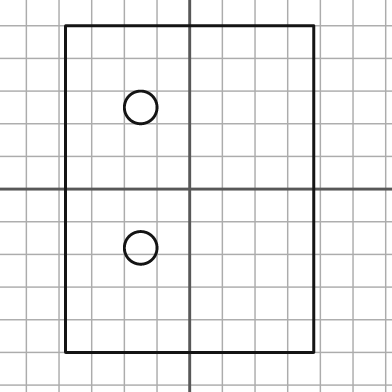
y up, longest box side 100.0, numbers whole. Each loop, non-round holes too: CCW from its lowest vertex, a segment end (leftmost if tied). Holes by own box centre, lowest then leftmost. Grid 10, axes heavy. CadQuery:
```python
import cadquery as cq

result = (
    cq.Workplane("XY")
    .moveTo(-38.0, -50.0)
    .lineTo(38.0, -50.0)
    .lineTo(38.0, 50.0)
    .lineTo(-38.0, 50.0)
    .close()
    .moveTo(-15.0, -18.0)
    .circle(5.0)
    .moveTo(-15.0, 25.0)
    .circle(5.0)
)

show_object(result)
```